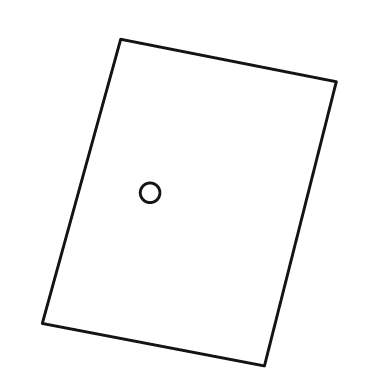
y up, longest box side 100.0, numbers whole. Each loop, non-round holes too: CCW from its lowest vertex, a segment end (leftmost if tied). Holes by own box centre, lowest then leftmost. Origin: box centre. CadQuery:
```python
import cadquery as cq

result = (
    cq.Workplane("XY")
    .moveTo(23.0, -50.0)
    .lineTo(45.0, 37.0)
    .lineTo(-21.0, 50.0)
    .lineTo(-45.0, -37.0)
    .close()
    .moveTo(-12.0, 3.0)
    .circle(3.0)
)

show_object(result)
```